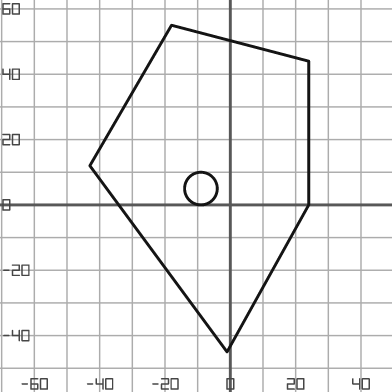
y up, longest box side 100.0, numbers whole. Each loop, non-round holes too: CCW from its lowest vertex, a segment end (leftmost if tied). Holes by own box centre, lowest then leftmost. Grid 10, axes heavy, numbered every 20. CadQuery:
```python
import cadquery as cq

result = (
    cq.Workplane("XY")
    .moveTo(-1.0, -45.0)
    .lineTo(24.0, 0.0)
    .lineTo(24.0, 44.0)
    .lineTo(-18.0, 55.0)
    .lineTo(-43.0, 12.0)
    .close()
    .moveTo(-9.0, 5.0)
    .circle(5.0)
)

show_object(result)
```